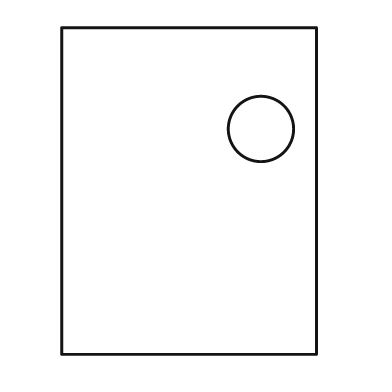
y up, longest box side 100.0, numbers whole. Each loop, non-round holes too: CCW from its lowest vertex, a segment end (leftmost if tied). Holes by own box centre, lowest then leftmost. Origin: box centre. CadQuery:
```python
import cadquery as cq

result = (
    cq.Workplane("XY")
    .moveTo(-39.0, -50.0)
    .lineTo(39.0, -50.0)
    .lineTo(39.0, 50.0)
    .lineTo(-39.0, 50.0)
    .close()
    .moveTo(22.0, 19.0)
    .circle(10.0)
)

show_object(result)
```